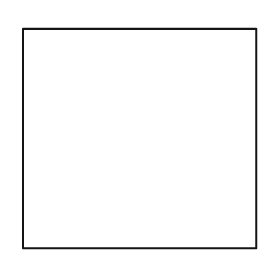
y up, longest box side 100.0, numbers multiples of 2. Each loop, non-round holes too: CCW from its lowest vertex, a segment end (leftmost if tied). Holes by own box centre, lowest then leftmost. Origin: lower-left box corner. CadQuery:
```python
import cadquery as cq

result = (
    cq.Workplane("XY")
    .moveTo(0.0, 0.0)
    .lineTo(100.0, 0.0)
    .lineTo(100.0, 94.0)
    .lineTo(0.0, 94.0)
    .close()
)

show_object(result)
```